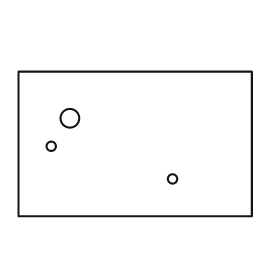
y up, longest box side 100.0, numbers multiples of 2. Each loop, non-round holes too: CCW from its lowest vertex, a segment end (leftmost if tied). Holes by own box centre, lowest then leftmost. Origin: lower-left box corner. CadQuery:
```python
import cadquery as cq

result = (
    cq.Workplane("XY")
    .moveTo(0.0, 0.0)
    .lineTo(100.0, 0.0)
    .lineTo(100.0, 62.0)
    .lineTo(0.0, 62.0)
    .close()
    .moveTo(66.0, 16.0)
    .circle(2.0)
    .moveTo(14.0, 30.0)
    .circle(2.0)
    .moveTo(22.0, 42.0)
    .circle(4.0)
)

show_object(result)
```